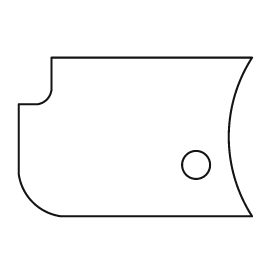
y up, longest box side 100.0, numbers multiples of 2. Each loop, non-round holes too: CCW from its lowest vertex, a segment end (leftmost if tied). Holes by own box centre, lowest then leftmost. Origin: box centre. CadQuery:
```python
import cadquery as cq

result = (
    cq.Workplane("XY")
    .moveTo(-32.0, -34.0)
    .lineTo(50.0, -34.0)
    .threePointArc((40.0, 0.0), (50.0, 34.0))
    .lineTo(-36.0, 34.0)
    .lineTo(-36.0, 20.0)
    .threePointArc((-38.0, 16.0), (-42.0, 14.0))
    .lineTo(-50.0, 14.0)
    .lineTo(-50.0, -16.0)
    .threePointArc((-44.0, -28.0), (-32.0, -34.0))
    .close()
    .moveTo(26.0, -12.0)
    .circle(6.0)
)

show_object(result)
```